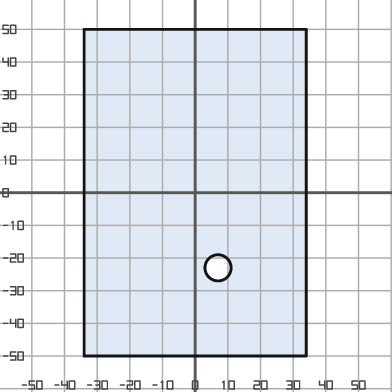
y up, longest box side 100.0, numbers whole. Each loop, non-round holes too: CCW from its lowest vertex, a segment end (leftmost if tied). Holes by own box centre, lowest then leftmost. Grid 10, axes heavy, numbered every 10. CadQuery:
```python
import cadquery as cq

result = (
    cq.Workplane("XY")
    .moveTo(-34.0, -50.0)
    .lineTo(34.0, -50.0)
    .lineTo(34.0, 50.0)
    .lineTo(-34.0, 50.0)
    .close()
    .moveTo(7.0, -23.0)
    .circle(4.0)
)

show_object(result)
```